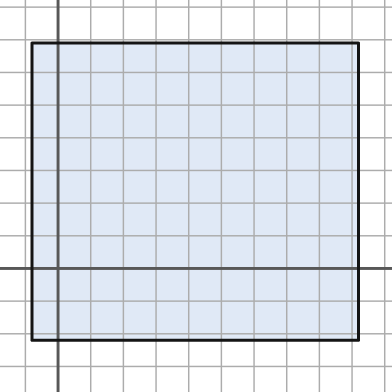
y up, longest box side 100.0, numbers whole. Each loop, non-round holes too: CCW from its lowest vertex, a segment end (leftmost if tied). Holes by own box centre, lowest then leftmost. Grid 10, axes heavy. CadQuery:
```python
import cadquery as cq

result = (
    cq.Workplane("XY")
    .moveTo(-8.0, -22.0)
    .lineTo(92.0, -22.0)
    .lineTo(92.0, 69.0)
    .lineTo(-8.0, 69.0)
    .close()
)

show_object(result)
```